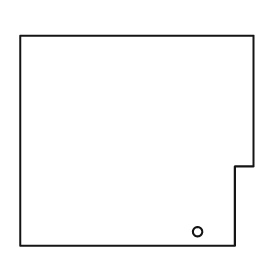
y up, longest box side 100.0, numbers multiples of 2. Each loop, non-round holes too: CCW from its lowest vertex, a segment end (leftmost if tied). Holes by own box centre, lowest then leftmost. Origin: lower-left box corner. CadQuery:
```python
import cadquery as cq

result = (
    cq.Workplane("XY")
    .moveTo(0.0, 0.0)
    .lineTo(92.0, 0.0)
    .lineTo(92.0, 34.0)
    .lineTo(100.0, 34.0)
    .lineTo(100.0, 90.0)
    .lineTo(0.0, 90.0)
    .close()
    .moveTo(76.0, 6.0)
    .circle(2.0)
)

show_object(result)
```